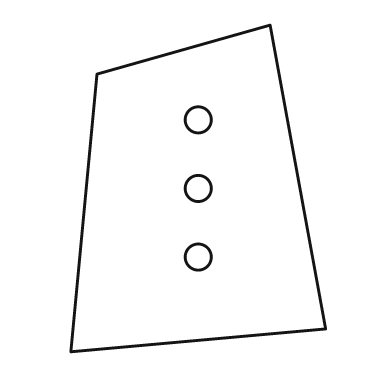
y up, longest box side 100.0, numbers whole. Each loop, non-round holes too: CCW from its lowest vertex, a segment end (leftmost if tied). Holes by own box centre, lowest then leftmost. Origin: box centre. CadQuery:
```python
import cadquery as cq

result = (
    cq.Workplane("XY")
    .moveTo(-39.0, -50.0)
    .lineTo(39.0, -43.0)
    .lineTo(22.0, 50.0)
    .lineTo(-31.0, 35.0)
    .close()
    .moveTo(0.0, -21.0)
    .circle(4.0)
    .moveTo(0.0, 0.0)
    .circle(4.0)
    .moveTo(0.0, 21.0)
    .circle(4.0)
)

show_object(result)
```